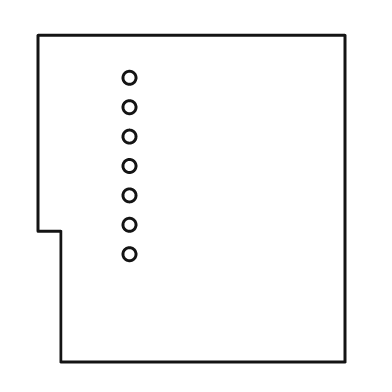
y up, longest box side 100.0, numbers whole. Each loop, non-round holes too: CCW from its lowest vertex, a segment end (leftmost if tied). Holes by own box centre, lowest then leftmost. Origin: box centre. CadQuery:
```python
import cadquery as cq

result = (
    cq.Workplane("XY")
    .moveTo(-40.0, -50.0)
    .lineTo(47.0, -50.0)
    .lineTo(47.0, 50.0)
    .lineTo(-47.0, 50.0)
    .lineTo(-47.0, -10.0)
    .lineTo(-40.0, -10.0)
    .close()
    .moveTo(-19.0, -17.0)
    .circle(2.0)
    .moveTo(-19.0, -8.0)
    .circle(2.0)
    .moveTo(-19.0, 1.0)
    .circle(2.0)
    .moveTo(-19.0, 10.0)
    .circle(2.0)
    .moveTo(-19.0, 19.0)
    .circle(2.0)
    .moveTo(-19.0, 28.0)
    .circle(2.0)
    .moveTo(-19.0, 37.0)
    .circle(2.0)
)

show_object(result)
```